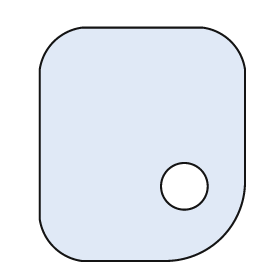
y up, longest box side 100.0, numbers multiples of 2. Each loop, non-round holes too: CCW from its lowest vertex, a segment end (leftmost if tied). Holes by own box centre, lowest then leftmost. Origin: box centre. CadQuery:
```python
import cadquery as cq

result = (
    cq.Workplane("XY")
    .moveTo(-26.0, -50.0)
    .lineTo(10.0, -50.0)
    .threePointArc((34.0, -40.0), (44.0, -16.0))
    .lineTo(44.0, 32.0)
    .threePointArc((38.0, 44.0), (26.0, 50.0))
    .lineTo(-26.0, 50.0)
    .threePointArc((-38.0, 44.0), (-44.0, 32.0))
    .lineTo(-44.0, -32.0)
    .threePointArc((-38.0, -44.0), (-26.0, -50.0))
    .close()
    .moveTo(18.0, -18.0)
    .circle(10.0)
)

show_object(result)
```